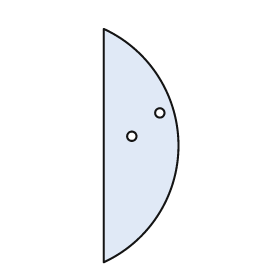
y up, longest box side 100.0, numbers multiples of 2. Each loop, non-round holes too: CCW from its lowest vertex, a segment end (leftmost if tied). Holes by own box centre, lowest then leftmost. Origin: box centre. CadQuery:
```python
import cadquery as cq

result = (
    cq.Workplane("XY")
    .moveTo(-16.0, -50.0)
    .threePointArc((16.0, 0.0), (-16.0, 50.0))
    .close()
    .moveTo(-4.0, 4.0)
    .circle(2.0)
    .moveTo(8.0, 14.0)
    .circle(2.0)
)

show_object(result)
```